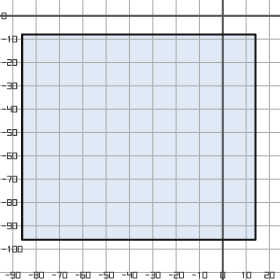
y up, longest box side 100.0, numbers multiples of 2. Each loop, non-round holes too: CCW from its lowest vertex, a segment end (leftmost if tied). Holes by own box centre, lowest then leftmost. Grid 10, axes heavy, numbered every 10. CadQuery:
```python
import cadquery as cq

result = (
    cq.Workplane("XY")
    .moveTo(-86.0, -96.0)
    .lineTo(14.0, -96.0)
    .lineTo(14.0, -8.0)
    .lineTo(-86.0, -8.0)
    .close()
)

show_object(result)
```